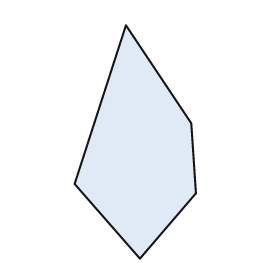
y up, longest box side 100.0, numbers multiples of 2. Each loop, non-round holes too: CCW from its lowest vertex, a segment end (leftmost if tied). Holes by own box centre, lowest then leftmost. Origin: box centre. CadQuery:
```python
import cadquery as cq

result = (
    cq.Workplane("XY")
    .moveTo(2.0, -50.0)
    .lineTo(26.0, -22.0)
    .lineTo(24.0, 8.0)
    .lineTo(-4.0, 50.0)
    .lineTo(-26.0, -18.0)
    .close()
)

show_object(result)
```